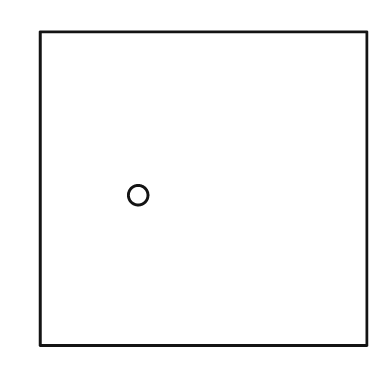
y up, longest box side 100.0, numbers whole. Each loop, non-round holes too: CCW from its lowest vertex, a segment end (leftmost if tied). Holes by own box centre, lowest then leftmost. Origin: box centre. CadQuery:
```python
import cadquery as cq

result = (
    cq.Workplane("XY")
    .moveTo(-50.0, -48.0)
    .lineTo(50.0, -48.0)
    .lineTo(50.0, 48.0)
    .lineTo(-50.0, 48.0)
    .close()
    .moveTo(-20.0, -2.0)
    .circle(3.0)
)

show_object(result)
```